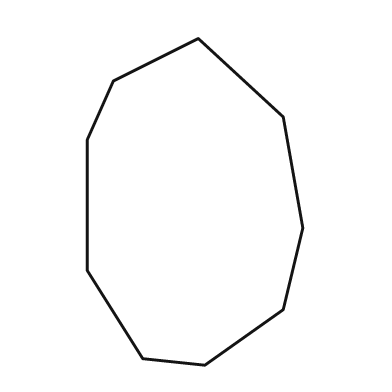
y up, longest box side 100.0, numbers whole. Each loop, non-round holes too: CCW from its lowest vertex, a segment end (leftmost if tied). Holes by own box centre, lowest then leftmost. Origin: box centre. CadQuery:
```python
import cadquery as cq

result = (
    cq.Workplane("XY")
    .moveTo(3.0, -50.0)
    .lineTo(27.0, -33.0)
    .lineTo(33.0, -8.0)
    .lineTo(27.0, 26.0)
    .lineTo(1.0, 50.0)
    .lineTo(-25.0, 37.0)
    .lineTo(-33.0, 19.0)
    .lineTo(-33.0, -21.0)
    .lineTo(-16.0, -48.0)
    .close()
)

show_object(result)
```